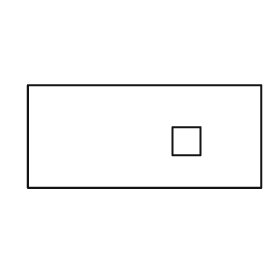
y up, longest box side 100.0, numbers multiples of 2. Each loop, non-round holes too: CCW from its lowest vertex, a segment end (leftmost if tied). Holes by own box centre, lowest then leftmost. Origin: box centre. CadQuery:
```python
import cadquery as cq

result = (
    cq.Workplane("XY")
    .moveTo(-50.0, -22.0)
    .lineTo(50.0, -22.0)
    .lineTo(50.0, 22.0)
    .lineTo(-50.0, 22.0)
    .close()
    .moveTo(12.0, -8.0)
    .lineTo(24.0, -8.0)
    .lineTo(24.0, 4.0)
    .lineTo(12.0, 4.0)
    .close()
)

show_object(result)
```